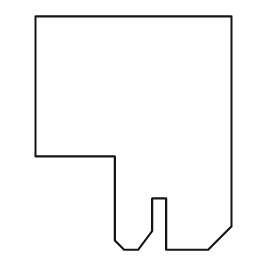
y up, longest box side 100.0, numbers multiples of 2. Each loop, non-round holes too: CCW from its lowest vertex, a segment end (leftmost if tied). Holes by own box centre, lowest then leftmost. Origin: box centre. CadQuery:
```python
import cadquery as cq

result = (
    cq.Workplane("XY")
    .moveTo(-4.0, -50.0)
    .lineTo(2.0, -50.0)
    .lineTo(8.0, -42.0)
    .lineTo(8.0, -28.0)
    .lineTo(14.0, -28.0)
    .lineTo(14.0, -50.0)
    .lineTo(32.0, -50.0)
    .lineTo(42.0, -40.0)
    .lineTo(42.0, 50.0)
    .lineTo(-42.0, 50.0)
    .lineTo(-42.0, -10.0)
    .lineTo(-8.0, -10.0)
    .lineTo(-8.0, -46.0)
    .close()
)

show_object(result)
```